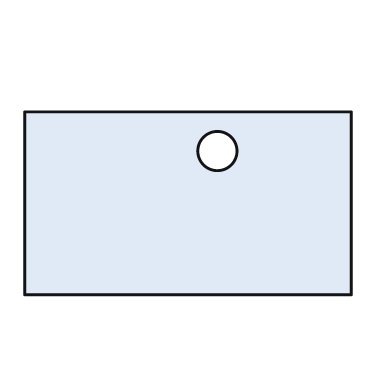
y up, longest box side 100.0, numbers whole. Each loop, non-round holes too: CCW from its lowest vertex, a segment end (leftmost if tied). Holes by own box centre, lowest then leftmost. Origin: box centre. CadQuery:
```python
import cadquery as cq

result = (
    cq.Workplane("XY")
    .moveTo(-50.0, -28.0)
    .lineTo(50.0, -28.0)
    .lineTo(50.0, 28.0)
    .lineTo(-50.0, 28.0)
    .close()
    .moveTo(9.0, 16.0)
    .circle(6.0)
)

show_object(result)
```